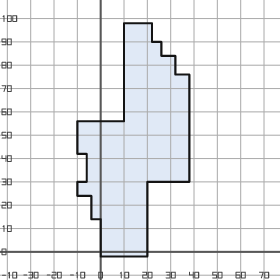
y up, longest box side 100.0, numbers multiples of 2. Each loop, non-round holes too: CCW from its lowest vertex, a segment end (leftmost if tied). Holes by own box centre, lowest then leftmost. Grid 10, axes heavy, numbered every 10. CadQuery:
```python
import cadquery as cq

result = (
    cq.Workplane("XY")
    .moveTo(0.0, -2.0)
    .lineTo(20.0, -2.0)
    .lineTo(20.0, 30.0)
    .lineTo(38.0, 30.0)
    .lineTo(38.0, 76.0)
    .lineTo(32.0, 76.0)
    .lineTo(32.0, 84.0)
    .lineTo(26.0, 84.0)
    .lineTo(26.0, 90.0)
    .lineTo(22.0, 90.0)
    .lineTo(22.0, 98.0)
    .lineTo(10.0, 98.0)
    .lineTo(10.0, 56.0)
    .lineTo(-10.0, 56.0)
    .lineTo(-10.0, 42.0)
    .lineTo(-6.0, 42.0)
    .lineTo(-6.0, 30.0)
    .lineTo(-10.0, 30.0)
    .lineTo(-10.0, 24.0)
    .lineTo(-4.0, 24.0)
    .lineTo(-4.0, 14.0)
    .lineTo(0.0, 14.0)
    .close()
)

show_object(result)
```